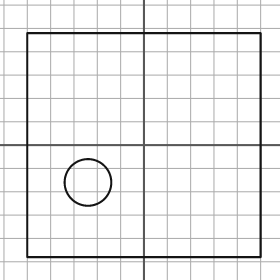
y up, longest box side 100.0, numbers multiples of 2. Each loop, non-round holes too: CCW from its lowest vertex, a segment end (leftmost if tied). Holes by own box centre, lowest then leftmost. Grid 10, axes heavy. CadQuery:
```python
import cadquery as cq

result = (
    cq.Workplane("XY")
    .moveTo(-50.0, -48.0)
    .lineTo(50.0, -48.0)
    .lineTo(50.0, 48.0)
    .lineTo(-50.0, 48.0)
    .close()
    .moveTo(-24.0, -16.0)
    .circle(10.0)
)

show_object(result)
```